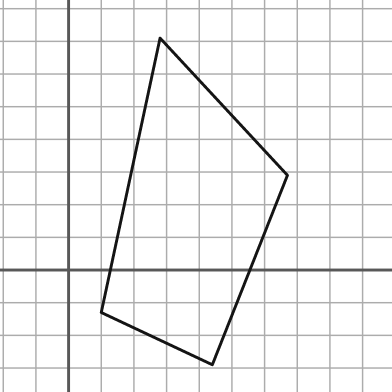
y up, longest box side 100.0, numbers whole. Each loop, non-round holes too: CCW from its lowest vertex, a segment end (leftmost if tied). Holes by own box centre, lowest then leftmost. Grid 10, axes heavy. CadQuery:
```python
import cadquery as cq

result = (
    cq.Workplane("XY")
    .moveTo(44.0, -29.0)
    .lineTo(67.0, 29.0)
    .lineTo(28.0, 71.0)
    .lineTo(10.0, -13.0)
    .close()
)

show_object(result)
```